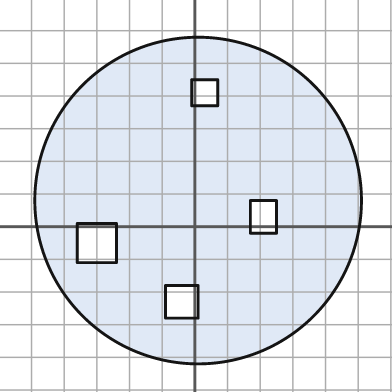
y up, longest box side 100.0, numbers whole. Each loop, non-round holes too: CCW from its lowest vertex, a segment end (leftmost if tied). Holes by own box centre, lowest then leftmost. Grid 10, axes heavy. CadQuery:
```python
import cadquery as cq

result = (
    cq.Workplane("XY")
    .moveTo(1.0, 8.0)
    .circle(50.0)
    .moveTo(-9.0, -28.0)
    .lineTo(1.0, -28.0)
    .lineTo(1.0, -18.0)
    .lineTo(-9.0, -18.0)
    .close()
    .moveTo(-36.0, -11.0)
    .lineTo(-24.0, -11.0)
    .lineTo(-24.0, 1.0)
    .lineTo(-36.0, 1.0)
    .close()
    .moveTo(17.0, -2.0)
    .lineTo(25.0, -2.0)
    .lineTo(25.0, 8.0)
    .lineTo(17.0, 8.0)
    .close()
    .moveTo(-1.0, 37.0)
    .lineTo(7.0, 37.0)
    .lineTo(7.0, 45.0)
    .lineTo(-1.0, 45.0)
    .close()
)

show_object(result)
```